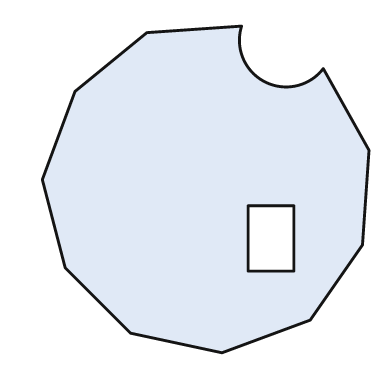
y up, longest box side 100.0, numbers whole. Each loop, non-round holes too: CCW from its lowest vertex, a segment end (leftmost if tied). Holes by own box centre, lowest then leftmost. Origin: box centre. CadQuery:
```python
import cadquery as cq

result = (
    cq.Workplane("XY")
    .moveTo(5.0, -50.0)
    .lineTo(32.0, -40.0)
    .lineTo(48.0, -17.0)
    .lineTo(50.0, 12.0)
    .lineTo(36.0, 37.0)
    .threePointArc((18.0, 33.0), (11.0, 50.0))
    .lineTo(-18.0, 48.0)
    .lineTo(-40.0, 30.0)
    .lineTo(-50.0, 3.0)
    .lineTo(-43.0, -24.0)
    .lineTo(-23.0, -44.0)
    .close()
    .moveTo(13.0, -25.0)
    .lineTo(27.0, -25.0)
    .lineTo(27.0, -5.0)
    .lineTo(13.0, -5.0)
    .close()
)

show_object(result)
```